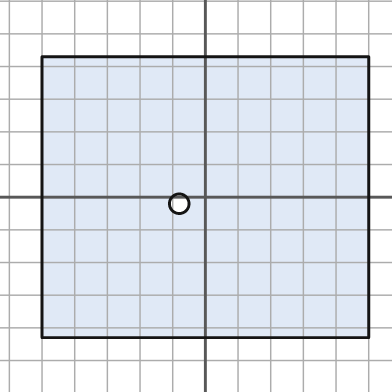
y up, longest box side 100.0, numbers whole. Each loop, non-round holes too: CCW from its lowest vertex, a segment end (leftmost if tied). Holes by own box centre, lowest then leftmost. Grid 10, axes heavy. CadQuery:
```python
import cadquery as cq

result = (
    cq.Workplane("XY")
    .moveTo(-50.0, -43.0)
    .lineTo(50.0, -43.0)
    .lineTo(50.0, 43.0)
    .lineTo(-50.0, 43.0)
    .close()
    .moveTo(-8.0, -2.0)
    .circle(3.0)
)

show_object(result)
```